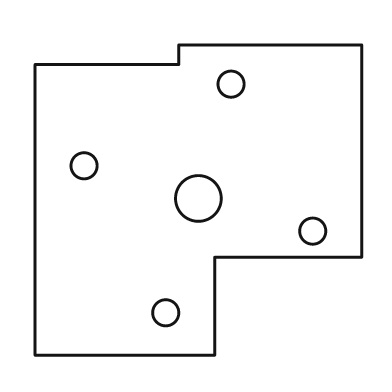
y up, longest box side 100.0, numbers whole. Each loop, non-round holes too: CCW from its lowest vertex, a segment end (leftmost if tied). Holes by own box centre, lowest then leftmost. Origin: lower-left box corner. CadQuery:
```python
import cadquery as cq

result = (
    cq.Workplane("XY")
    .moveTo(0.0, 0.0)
    .lineTo(55.0, 0.0)
    .lineTo(55.0, 30.0)
    .lineTo(100.0, 30.0)
    .lineTo(100.0, 95.0)
    .lineTo(44.0, 95.0)
    .lineTo(44.0, 89.0)
    .lineTo(0.0, 89.0)
    .close()
    .moveTo(40.0, 13.0)
    .circle(4.0)
    .moveTo(85.0, 38.0)
    .circle(4.0)
    .moveTo(50.0, 48.0)
    .circle(7.0)
    .moveTo(15.0, 58.0)
    .circle(4.0)
    .moveTo(60.0, 83.0)
    .circle(4.0)
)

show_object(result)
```